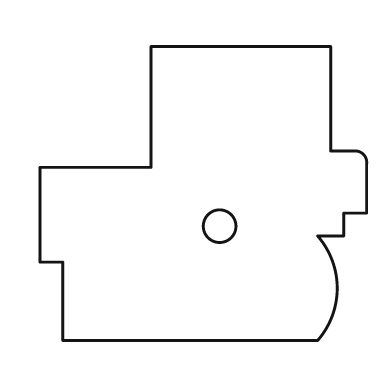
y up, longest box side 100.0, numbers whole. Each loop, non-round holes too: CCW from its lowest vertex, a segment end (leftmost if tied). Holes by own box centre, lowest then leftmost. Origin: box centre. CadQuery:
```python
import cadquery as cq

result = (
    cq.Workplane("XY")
    .moveTo(-43.0, -45.0)
    .lineTo(35.0, -45.0)
    .threePointArc((41.0, -29.0), (35.0, -13.0))
    .lineTo(43.0, -13.0)
    .lineTo(43.0, -6.0)
    .lineTo(50.0, -6.0)
    .lineTo(50.0, 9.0)
    .threePointArc((49.0, 12.0), (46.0, 13.0))
    .lineTo(39.0, 13.0)
    .lineTo(39.0, 45.0)
    .lineTo(-16.0, 45.0)
    .lineTo(-16.0, 8.0)
    .lineTo(-50.0, 8.0)
    .lineTo(-50.0, -21.0)
    .lineTo(-43.0, -21.0)
    .close()
    .moveTo(5.0, -10.0)
    .circle(5.0)
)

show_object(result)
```